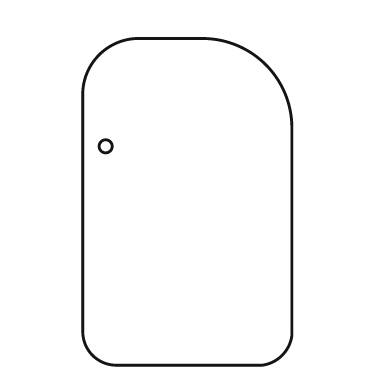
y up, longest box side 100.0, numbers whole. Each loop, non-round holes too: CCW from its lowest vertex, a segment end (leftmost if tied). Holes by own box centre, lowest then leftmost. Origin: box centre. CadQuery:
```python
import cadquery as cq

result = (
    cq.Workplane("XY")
    .moveTo(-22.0, -50.0)
    .lineTo(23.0, -50.0)
    .threePointArc((29.0, -47.0), (32.0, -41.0))
    .lineTo(32.0, 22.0)
    .threePointArc((24.0, 42.0), (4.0, 50.0))
    .lineTo(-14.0, 50.0)
    .threePointArc((-27.0, 45.0), (-32.0, 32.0))
    .lineTo(-32.0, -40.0)
    .threePointArc((-29.0, -47.0), (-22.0, -50.0))
    .close()
    .moveTo(-25.0, 17.0)
    .circle(2.0)
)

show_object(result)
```